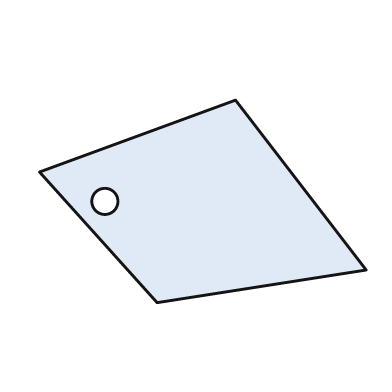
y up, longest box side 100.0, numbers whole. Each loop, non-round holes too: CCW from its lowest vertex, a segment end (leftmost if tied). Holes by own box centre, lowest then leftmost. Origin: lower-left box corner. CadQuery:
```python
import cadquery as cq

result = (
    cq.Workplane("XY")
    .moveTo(36.0, 0.0)
    .lineTo(100.0, 10.0)
    .lineTo(60.0, 62.0)
    .lineTo(0.0, 40.0)
    .close()
    .moveTo(20.0, 31.0)
    .circle(4.0)
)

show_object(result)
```